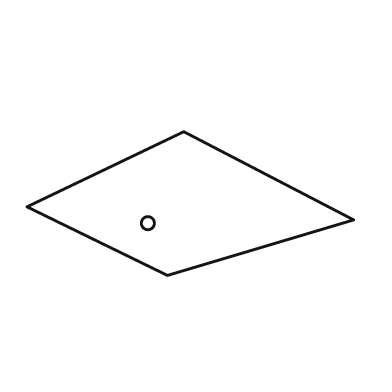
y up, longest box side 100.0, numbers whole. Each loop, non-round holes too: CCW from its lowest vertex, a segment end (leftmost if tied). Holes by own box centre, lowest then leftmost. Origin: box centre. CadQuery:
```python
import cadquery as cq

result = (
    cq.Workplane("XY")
    .moveTo(-7.0, -22.0)
    .lineTo(50.0, -5.0)
    .lineTo(-2.0, 22.0)
    .lineTo(-50.0, -1.0)
    .close()
    .moveTo(-13.0, -6.0)
    .circle(2.0)
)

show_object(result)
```